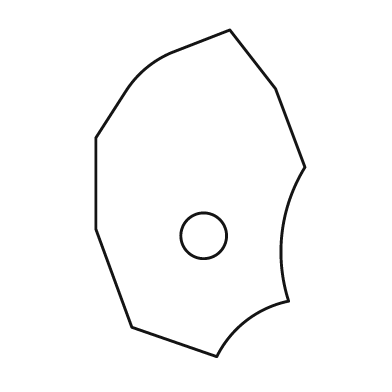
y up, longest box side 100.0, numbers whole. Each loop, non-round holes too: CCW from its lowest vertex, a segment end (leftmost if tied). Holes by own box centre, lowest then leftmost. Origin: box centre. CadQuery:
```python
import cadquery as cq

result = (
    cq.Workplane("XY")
    .moveTo(5.0, -50.0)
    .threePointArc((14.0, -39.0), (27.0, -33.0))
    .threePointArc((25.0, -12.0), (32.0, 8.0))
    .lineTo(23.0, 32.0)
    .lineTo(9.0, 50.0)
    .lineTo(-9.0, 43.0)
    .threePointArc((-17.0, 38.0), (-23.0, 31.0))
    .lineTo(-32.0, 17.0)
    .lineTo(-32.0, -11.0)
    .lineTo(-21.0, -41.0)
    .close()
    .moveTo(1.0, -13.0)
    .circle(7.0)
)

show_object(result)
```